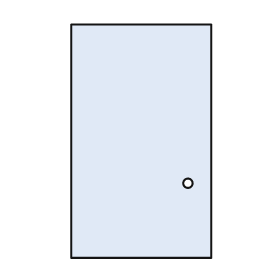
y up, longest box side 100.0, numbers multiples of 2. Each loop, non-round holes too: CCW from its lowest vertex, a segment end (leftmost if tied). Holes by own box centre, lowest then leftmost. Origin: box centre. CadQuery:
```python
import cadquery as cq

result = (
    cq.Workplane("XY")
    .moveTo(-30.0, -50.0)
    .lineTo(30.0, -50.0)
    .lineTo(30.0, 50.0)
    .lineTo(-30.0, 50.0)
    .close()
    .moveTo(20.0, -18.0)
    .circle(2.0)
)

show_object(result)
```